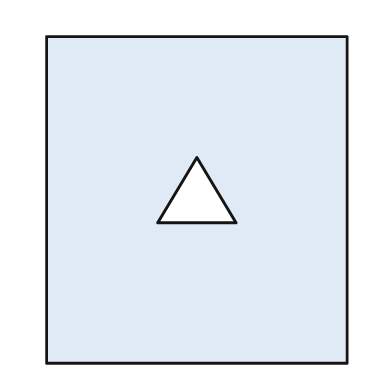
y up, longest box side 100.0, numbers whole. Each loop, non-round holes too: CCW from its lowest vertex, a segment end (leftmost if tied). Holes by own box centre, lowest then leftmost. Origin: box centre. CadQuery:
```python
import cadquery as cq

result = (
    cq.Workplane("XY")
    .moveTo(-46.0, -50.0)
    .lineTo(46.0, -50.0)
    .lineTo(46.0, 50.0)
    .lineTo(-46.0, 50.0)
    .close()
    .moveTo(-12.0, -7.0)
    .lineTo(12.0, -7.0)
    .lineTo(0.0, 13.0)
    .close()
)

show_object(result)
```